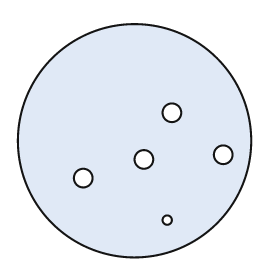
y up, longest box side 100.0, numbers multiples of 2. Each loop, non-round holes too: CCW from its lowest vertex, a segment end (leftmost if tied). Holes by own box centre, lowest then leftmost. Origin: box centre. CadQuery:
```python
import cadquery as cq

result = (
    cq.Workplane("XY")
    .moveTo(0.0, 0.0)
    .circle(50.0)
    .moveTo(14.0, -34.0)
    .circle(2.0)
    .moveTo(-22.0, -16.0)
    .circle(4.0)
    .moveTo(4.0, -8.0)
    .circle(4.0)
    .moveTo(38.0, -6.0)
    .circle(4.0)
    .moveTo(16.0, 12.0)
    .circle(4.0)
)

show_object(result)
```